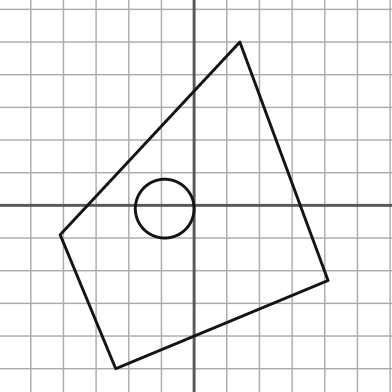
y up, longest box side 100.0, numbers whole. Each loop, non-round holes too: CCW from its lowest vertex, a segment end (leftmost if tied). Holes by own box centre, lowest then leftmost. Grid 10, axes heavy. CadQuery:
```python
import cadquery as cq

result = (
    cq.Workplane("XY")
    .moveTo(-24.0, -50.0)
    .lineTo(41.0, -23.0)
    .lineTo(14.0, 50.0)
    .lineTo(-41.0, -9.0)
    .close()
    .moveTo(-9.0, -1.0)
    .circle(9.0)
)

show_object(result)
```